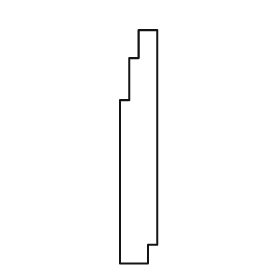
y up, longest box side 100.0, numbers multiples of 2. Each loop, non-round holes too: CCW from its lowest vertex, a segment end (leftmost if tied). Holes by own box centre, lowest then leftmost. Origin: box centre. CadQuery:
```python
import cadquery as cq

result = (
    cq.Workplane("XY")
    .moveTo(-8.0, -50.0)
    .lineTo(4.0, -50.0)
    .lineTo(4.0, -42.0)
    .lineTo(8.0, -42.0)
    .lineTo(8.0, 50.0)
    .lineTo(0.0, 50.0)
    .lineTo(0.0, 38.0)
    .lineTo(-4.0, 38.0)
    .lineTo(-4.0, 20.0)
    .lineTo(-8.0, 20.0)
    .close()
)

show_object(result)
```